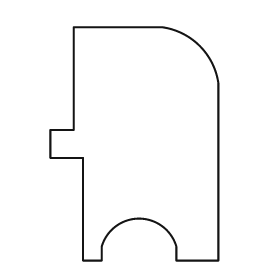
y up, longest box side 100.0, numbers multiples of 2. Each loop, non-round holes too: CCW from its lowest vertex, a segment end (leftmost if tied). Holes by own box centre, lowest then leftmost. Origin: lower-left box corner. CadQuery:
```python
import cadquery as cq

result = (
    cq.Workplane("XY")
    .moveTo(14.0, 0.0)
    .lineTo(22.0, 0.0)
    .lineTo(22.0, 6.0)
    .threePointArc((38.0, 18.0), (54.0, 6.0))
    .lineTo(54.0, 0.0)
    .lineTo(72.0, 0.0)
    .lineTo(72.0, 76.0)
    .threePointArc((64.0, 92.0), (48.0, 100.0))
    .lineTo(10.0, 100.0)
    .lineTo(10.0, 56.0)
    .lineTo(0.0, 56.0)
    .lineTo(0.0, 44.0)
    .lineTo(14.0, 44.0)
    .close()
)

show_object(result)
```